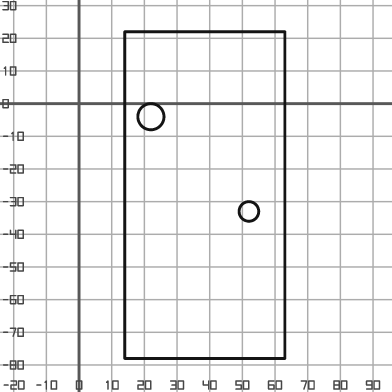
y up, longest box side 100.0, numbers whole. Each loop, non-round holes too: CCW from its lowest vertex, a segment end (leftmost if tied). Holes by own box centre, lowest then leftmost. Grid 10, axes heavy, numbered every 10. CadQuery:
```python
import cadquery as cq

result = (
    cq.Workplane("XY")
    .moveTo(14.0, -78.0)
    .lineTo(63.0, -78.0)
    .lineTo(63.0, 22.0)
    .lineTo(14.0, 22.0)
    .close()
    .moveTo(52.0, -33.0)
    .circle(3.0)
    .moveTo(22.0, -4.0)
    .circle(4.0)
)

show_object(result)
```